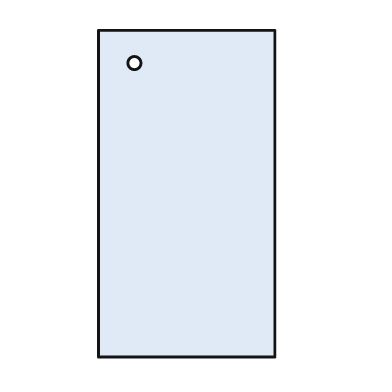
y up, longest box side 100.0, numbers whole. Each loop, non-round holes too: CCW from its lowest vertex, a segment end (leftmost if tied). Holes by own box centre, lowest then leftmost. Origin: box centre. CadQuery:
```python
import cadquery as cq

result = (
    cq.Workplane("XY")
    .moveTo(-27.0, -50.0)
    .lineTo(27.0, -50.0)
    .lineTo(27.0, 50.0)
    .lineTo(-27.0, 50.0)
    .close()
    .moveTo(-16.0, 40.0)
    .circle(2.0)
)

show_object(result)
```